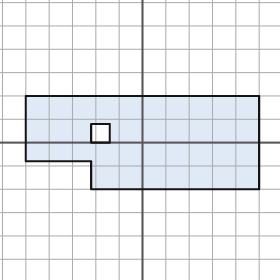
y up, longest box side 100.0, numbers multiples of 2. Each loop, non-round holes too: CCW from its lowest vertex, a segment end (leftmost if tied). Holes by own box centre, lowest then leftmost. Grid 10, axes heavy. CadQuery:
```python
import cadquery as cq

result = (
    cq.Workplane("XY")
    .moveTo(-22.0, -20.0)
    .lineTo(50.0, -20.0)
    .lineTo(50.0, 20.0)
    .lineTo(-50.0, 20.0)
    .lineTo(-50.0, -8.0)
    .lineTo(-22.0, -8.0)
    .close()
    .moveTo(-22.0, 0.0)
    .lineTo(-14.0, 0.0)
    .lineTo(-14.0, 8.0)
    .lineTo(-22.0, 8.0)
    .close()
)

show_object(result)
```